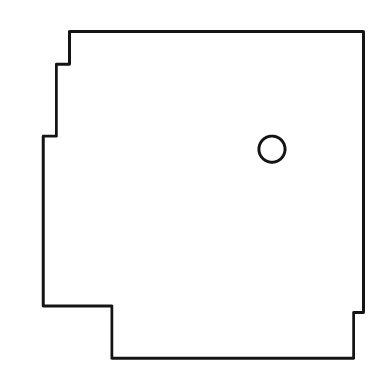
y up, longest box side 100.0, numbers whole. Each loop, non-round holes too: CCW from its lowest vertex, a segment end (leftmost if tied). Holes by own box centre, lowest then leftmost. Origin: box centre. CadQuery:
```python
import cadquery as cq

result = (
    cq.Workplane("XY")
    .moveTo(-28.0, -50.0)
    .lineTo(46.0, -50.0)
    .lineTo(46.0, -36.0)
    .lineTo(49.0, -36.0)
    .lineTo(49.0, 50.0)
    .lineTo(-41.0, 50.0)
    .lineTo(-41.0, 40.0)
    .lineTo(-45.0, 40.0)
    .lineTo(-45.0, 18.0)
    .lineTo(-49.0, 18.0)
    .lineTo(-49.0, -34.0)
    .lineTo(-28.0, -34.0)
    .close()
    .moveTo(21.0, 14.0)
    .circle(4.0)
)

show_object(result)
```